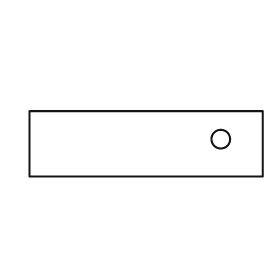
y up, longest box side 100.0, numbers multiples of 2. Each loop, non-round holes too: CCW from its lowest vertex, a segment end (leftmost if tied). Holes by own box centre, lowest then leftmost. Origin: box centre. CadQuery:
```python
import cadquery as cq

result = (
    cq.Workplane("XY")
    .moveTo(-50.0, -14.0)
    .lineTo(50.0, -14.0)
    .lineTo(50.0, 14.0)
    .lineTo(-50.0, 14.0)
    .close()
    .moveTo(32.0, 2.0)
    .circle(4.0)
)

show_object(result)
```